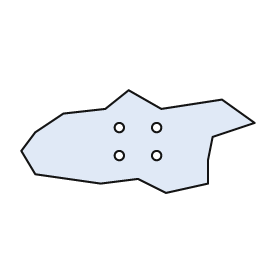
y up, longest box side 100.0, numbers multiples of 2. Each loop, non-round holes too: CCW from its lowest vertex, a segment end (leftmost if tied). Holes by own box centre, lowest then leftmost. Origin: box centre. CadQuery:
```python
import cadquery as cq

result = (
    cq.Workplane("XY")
    .moveTo(12.0, -22.0)
    .lineTo(30.0, -18.0)
    .lineTo(30.0, -8.0)
    .lineTo(32.0, 2.0)
    .lineTo(50.0, 8.0)
    .lineTo(36.0, 18.0)
    .lineTo(10.0, 14.0)
    .lineTo(-4.0, 22.0)
    .lineTo(-14.0, 14.0)
    .lineTo(-32.0, 12.0)
    .lineTo(-44.0, 4.0)
    .lineTo(-50.0, -4.0)
    .lineTo(-44.0, -14.0)
    .lineTo(-16.0, -18.0)
    .lineTo(0.0, -16.0)
    .close()
    .moveTo(-8.0, -6.0)
    .circle(2.0)
    .moveTo(8.0, -6.0)
    .circle(2.0)
    .moveTo(-8.0, 6.0)
    .circle(2.0)
    .moveTo(8.0, 6.0)
    .circle(2.0)
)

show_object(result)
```